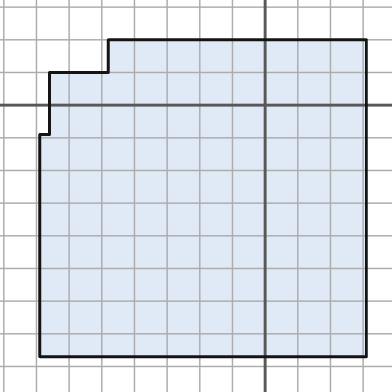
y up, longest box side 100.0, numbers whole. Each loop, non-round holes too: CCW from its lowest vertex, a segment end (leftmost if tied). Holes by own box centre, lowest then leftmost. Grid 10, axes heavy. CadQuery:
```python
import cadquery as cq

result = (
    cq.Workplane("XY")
    .moveTo(-69.0, -77.0)
    .lineTo(31.0, -77.0)
    .lineTo(31.0, 20.0)
    .lineTo(-48.0, 20.0)
    .lineTo(-48.0, 10.0)
    .lineTo(-66.0, 10.0)
    .lineTo(-66.0, -9.0)
    .lineTo(-69.0, -9.0)
    .close()
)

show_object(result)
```